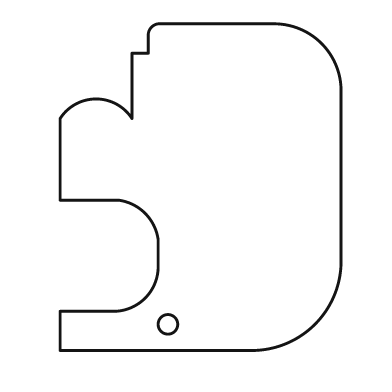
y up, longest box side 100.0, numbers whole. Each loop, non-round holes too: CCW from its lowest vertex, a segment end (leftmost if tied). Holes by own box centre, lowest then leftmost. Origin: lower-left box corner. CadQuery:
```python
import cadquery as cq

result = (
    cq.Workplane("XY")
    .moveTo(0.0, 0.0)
    .lineTo(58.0, 0.0)
    .threePointArc((78.0, 8.0), (86.0, 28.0))
    .lineTo(86.0, 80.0)
    .threePointArc((80.0, 94.0), (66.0, 100.0))
    .lineTo(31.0, 100.0)
    .threePointArc((28.0, 99.0), (27.0, 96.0))
    .lineTo(27.0, 91.0)
    .lineTo(22.0, 91.0)
    .lineTo(22.0, 71.0)
    .threePointArc((11.0, 77.0), (0.0, 71.0))
    .lineTo(0.0, 46.0)
    .lineTo(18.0, 46.0)
    .threePointArc((26.0, 42.0), (30.0, 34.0))
    .lineTo(30.0, 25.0)
    .threePointArc((26.0, 16.0), (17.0, 12.0))
    .lineTo(0.0, 12.0)
    .close()
    .moveTo(33.0, 8.0)
    .circle(3.0)
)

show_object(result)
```